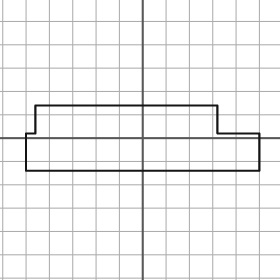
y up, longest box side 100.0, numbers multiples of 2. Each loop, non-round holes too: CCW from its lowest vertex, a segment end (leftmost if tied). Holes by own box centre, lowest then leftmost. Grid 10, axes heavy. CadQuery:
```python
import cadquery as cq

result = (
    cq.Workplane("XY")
    .moveTo(-50.0, -14.0)
    .lineTo(50.0, -14.0)
    .lineTo(50.0, 2.0)
    .lineTo(32.0, 2.0)
    .lineTo(32.0, 14.0)
    .lineTo(-46.0, 14.0)
    .lineTo(-46.0, 2.0)
    .lineTo(-50.0, 2.0)
    .close()
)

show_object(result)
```